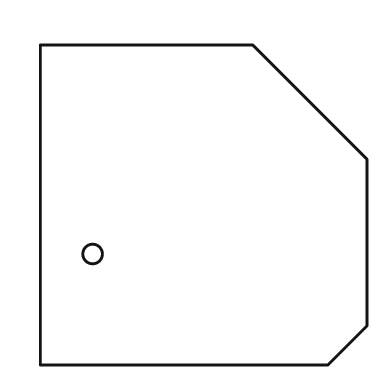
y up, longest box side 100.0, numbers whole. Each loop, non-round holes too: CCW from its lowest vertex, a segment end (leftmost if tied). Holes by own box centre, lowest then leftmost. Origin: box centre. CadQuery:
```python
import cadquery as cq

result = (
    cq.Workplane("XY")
    .moveTo(-50.0, -49.0)
    .lineTo(38.0, -49.0)
    .lineTo(50.0, -37.0)
    .lineTo(50.0, 14.0)
    .lineTo(15.0, 49.0)
    .lineTo(-50.0, 49.0)
    .close()
    .moveTo(-34.0, -15.0)
    .circle(3.0)
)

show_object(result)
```